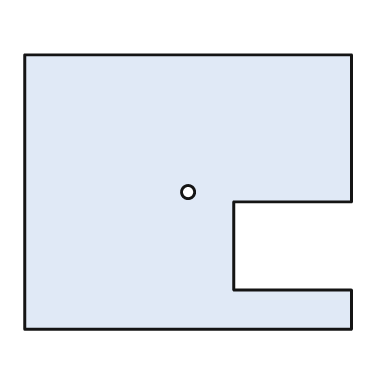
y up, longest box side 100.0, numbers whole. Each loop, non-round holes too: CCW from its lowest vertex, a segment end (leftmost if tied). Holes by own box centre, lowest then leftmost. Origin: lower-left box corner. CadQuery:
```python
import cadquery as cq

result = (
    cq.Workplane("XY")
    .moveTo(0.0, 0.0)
    .lineTo(100.0, 0.0)
    .lineTo(100.0, 12.0)
    .lineTo(64.0, 12.0)
    .lineTo(64.0, 39.0)
    .lineTo(100.0, 39.0)
    .lineTo(100.0, 84.0)
    .lineTo(0.0, 84.0)
    .close()
    .moveTo(50.0, 42.0)
    .circle(2.0)
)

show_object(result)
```